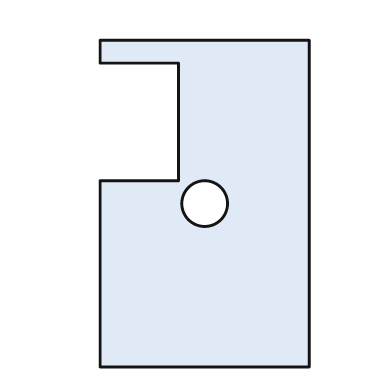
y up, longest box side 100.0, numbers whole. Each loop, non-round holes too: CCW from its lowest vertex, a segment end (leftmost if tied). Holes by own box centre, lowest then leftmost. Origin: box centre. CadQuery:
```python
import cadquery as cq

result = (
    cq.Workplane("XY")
    .moveTo(-32.0, -50.0)
    .lineTo(32.0, -50.0)
    .lineTo(32.0, 50.0)
    .lineTo(-32.0, 50.0)
    .lineTo(-32.0, 43.0)
    .lineTo(-8.0, 43.0)
    .lineTo(-8.0, 7.0)
    .lineTo(-32.0, 7.0)
    .close()
    .moveTo(0.0, 0.0)
    .circle(7.0)
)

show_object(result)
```